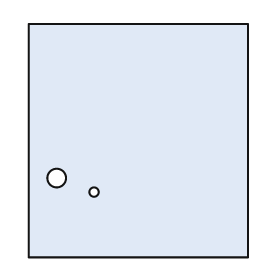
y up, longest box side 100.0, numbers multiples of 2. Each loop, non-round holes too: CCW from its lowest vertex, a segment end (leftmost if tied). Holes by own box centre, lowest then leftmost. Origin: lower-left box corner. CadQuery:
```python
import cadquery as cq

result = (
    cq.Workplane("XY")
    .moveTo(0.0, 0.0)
    .lineTo(94.0, 0.0)
    .lineTo(94.0, 100.0)
    .lineTo(0.0, 100.0)
    .close()
    .moveTo(28.0, 28.0)
    .circle(2.0)
    .moveTo(12.0, 34.0)
    .circle(4.0)
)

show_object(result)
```